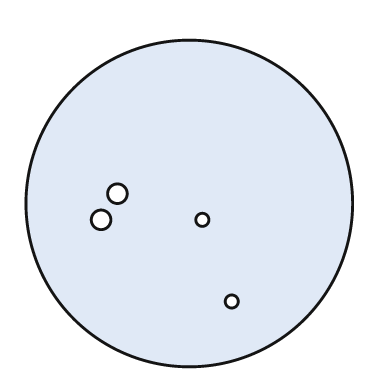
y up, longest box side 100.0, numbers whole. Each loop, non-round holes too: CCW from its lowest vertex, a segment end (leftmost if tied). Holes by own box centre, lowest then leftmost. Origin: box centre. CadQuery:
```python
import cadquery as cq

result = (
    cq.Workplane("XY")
    .moveTo(0.0, 0.0)
    .circle(50.0)
    .moveTo(13.0, -30.0)
    .circle(2.0)
    .moveTo(-27.0, -5.0)
    .circle(3.0)
    .moveTo(4.0, -5.0)
    .circle(2.0)
    .moveTo(-22.0, 3.0)
    .circle(3.0)
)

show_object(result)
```